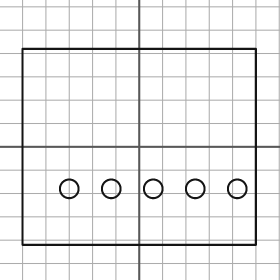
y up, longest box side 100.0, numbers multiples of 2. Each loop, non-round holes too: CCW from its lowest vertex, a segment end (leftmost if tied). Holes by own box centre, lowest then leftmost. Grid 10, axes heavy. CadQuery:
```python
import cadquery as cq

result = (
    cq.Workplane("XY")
    .moveTo(-50.0, -42.0)
    .lineTo(50.0, -42.0)
    .lineTo(50.0, 42.0)
    .lineTo(-50.0, 42.0)
    .close()
    .moveTo(-30.0, -18.0)
    .circle(4.0)
    .moveTo(-12.0, -18.0)
    .circle(4.0)
    .moveTo(6.0, -18.0)
    .circle(4.0)
    .moveTo(24.0, -18.0)
    .circle(4.0)
    .moveTo(42.0, -18.0)
    .circle(4.0)
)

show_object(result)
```